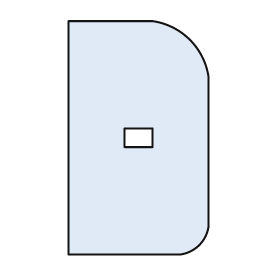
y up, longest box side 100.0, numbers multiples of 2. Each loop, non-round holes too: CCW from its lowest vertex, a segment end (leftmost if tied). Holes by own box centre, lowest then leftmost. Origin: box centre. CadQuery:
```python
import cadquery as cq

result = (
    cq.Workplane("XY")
    .moveTo(-30.0, -50.0)
    .lineTo(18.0, -50.0)
    .threePointArc((26.0, -46.0), (30.0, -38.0))
    .lineTo(30.0, 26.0)
    .threePointArc((22.0, 42.0), (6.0, 50.0))
    .lineTo(-30.0, 50.0)
    .close()
    .moveTo(-6.0, -4.0)
    .lineTo(6.0, -4.0)
    .lineTo(6.0, 4.0)
    .lineTo(-6.0, 4.0)
    .close()
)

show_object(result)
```